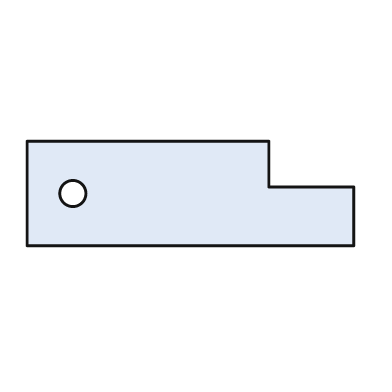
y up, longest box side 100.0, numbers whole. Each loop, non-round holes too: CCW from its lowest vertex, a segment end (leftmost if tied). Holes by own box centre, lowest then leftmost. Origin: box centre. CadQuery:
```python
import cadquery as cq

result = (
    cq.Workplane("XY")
    .moveTo(-50.0, -16.0)
    .lineTo(50.0, -16.0)
    .lineTo(50.0, 2.0)
    .lineTo(24.0, 2.0)
    .lineTo(24.0, 16.0)
    .lineTo(-50.0, 16.0)
    .close()
    .moveTo(-36.0, 0.0)
    .circle(4.0)
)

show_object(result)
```